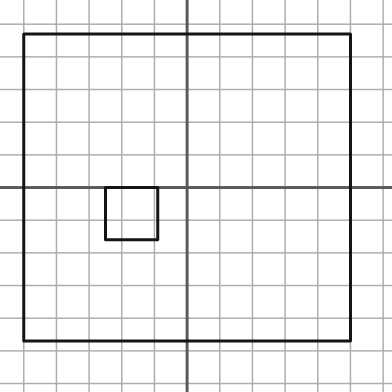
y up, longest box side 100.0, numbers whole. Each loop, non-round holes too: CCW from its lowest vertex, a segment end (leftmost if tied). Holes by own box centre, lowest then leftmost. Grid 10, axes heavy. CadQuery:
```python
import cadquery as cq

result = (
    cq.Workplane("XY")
    .moveTo(-50.0, -47.0)
    .lineTo(50.0, -47.0)
    .lineTo(50.0, 47.0)
    .lineTo(-50.0, 47.0)
    .close()
    .moveTo(-25.0, -16.0)
    .lineTo(-9.0, -16.0)
    .lineTo(-9.0, 0.0)
    .lineTo(-25.0, 0.0)
    .close()
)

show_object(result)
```